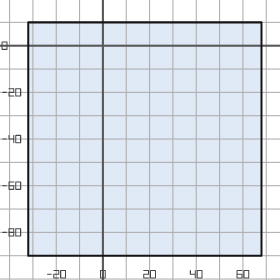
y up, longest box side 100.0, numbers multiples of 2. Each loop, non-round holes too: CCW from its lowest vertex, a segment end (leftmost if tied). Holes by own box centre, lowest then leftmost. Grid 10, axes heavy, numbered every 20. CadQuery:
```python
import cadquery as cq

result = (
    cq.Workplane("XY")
    .moveTo(-32.0, -90.0)
    .lineTo(68.0, -90.0)
    .lineTo(68.0, 10.0)
    .lineTo(-32.0, 10.0)
    .close()
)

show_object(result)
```